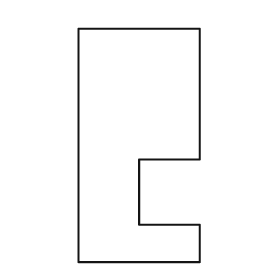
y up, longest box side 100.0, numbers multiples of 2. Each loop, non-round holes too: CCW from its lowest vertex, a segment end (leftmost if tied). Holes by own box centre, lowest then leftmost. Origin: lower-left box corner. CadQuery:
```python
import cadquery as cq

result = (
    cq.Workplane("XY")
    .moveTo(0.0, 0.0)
    .lineTo(52.0, 0.0)
    .lineTo(52.0, 16.0)
    .lineTo(26.0, 16.0)
    .lineTo(26.0, 44.0)
    .lineTo(52.0, 44.0)
    .lineTo(52.0, 100.0)
    .lineTo(0.0, 100.0)
    .close()
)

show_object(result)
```